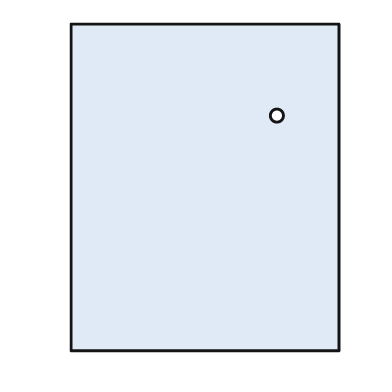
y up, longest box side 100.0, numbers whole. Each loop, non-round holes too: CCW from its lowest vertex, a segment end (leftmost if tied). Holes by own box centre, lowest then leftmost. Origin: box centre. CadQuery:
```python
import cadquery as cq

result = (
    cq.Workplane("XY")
    .moveTo(-41.0, -50.0)
    .lineTo(41.0, -50.0)
    .lineTo(41.0, 50.0)
    .lineTo(-41.0, 50.0)
    .close()
    .moveTo(22.0, 22.0)
    .circle(2.0)
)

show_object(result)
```